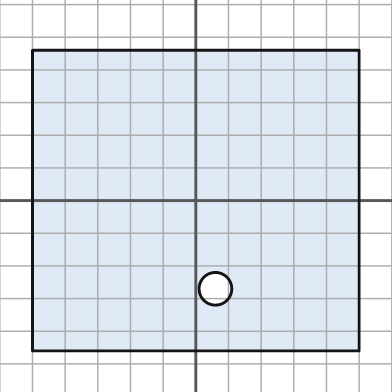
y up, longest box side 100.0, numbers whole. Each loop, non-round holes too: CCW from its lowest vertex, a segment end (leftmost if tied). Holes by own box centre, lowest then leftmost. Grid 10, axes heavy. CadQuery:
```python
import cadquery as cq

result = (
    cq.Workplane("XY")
    .moveTo(-50.0, -46.0)
    .lineTo(50.0, -46.0)
    .lineTo(50.0, 46.0)
    .lineTo(-50.0, 46.0)
    .close()
    .moveTo(6.0, -27.0)
    .circle(5.0)
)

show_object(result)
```